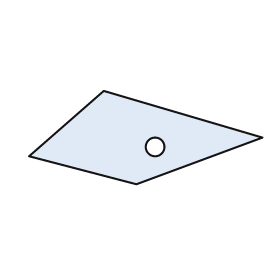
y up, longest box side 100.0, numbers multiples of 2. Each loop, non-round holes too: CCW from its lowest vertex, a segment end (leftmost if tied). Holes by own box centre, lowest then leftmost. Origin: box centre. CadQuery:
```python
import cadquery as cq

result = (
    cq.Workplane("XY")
    .moveTo(-4.0, -20.0)
    .lineTo(50.0, 0.0)
    .lineTo(-18.0, 20.0)
    .lineTo(-50.0, -8.0)
    .close()
    .moveTo(4.0, -4.0)
    .circle(4.0)
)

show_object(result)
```